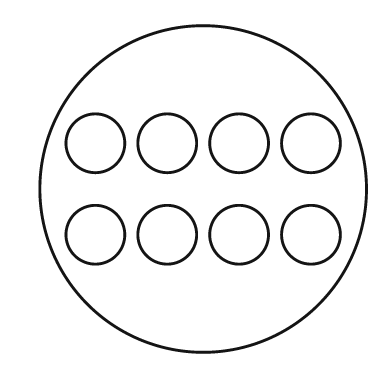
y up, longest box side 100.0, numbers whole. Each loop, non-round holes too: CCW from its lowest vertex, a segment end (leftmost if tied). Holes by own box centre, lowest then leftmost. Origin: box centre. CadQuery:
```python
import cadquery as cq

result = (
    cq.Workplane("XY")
    .moveTo(0.0, 0.0)
    .circle(50.0)
    .moveTo(-33.0, -14.0)
    .circle(9.0)
    .moveTo(-11.0, -14.0)
    .circle(9.0)
    .moveTo(11.0, -14.0)
    .circle(9.0)
    .moveTo(33.0, -14.0)
    .circle(9.0)
    .moveTo(-33.0, 14.0)
    .circle(9.0)
    .moveTo(-11.0, 14.0)
    .circle(9.0)
    .moveTo(11.0, 14.0)
    .circle(9.0)
    .moveTo(33.0, 14.0)
    .circle(9.0)
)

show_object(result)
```